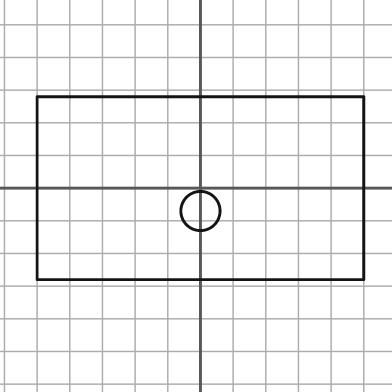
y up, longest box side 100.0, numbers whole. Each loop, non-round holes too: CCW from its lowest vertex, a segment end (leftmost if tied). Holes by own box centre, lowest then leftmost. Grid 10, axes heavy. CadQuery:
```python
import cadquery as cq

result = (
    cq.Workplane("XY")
    .moveTo(-50.0, -28.0)
    .lineTo(50.0, -28.0)
    .lineTo(50.0, 28.0)
    .lineTo(-50.0, 28.0)
    .close()
    .moveTo(0.0, -7.0)
    .circle(6.0)
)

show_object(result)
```